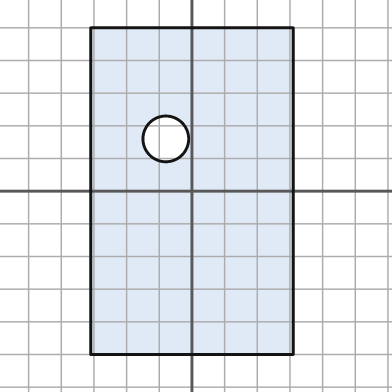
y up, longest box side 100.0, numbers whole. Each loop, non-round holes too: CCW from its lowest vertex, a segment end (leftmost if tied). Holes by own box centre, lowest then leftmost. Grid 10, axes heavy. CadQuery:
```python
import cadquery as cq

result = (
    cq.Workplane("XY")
    .moveTo(-31.0, -50.0)
    .lineTo(31.0, -50.0)
    .lineTo(31.0, 50.0)
    .lineTo(-31.0, 50.0)
    .close()
    .moveTo(-8.0, 16.0)
    .circle(7.0)
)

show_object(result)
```